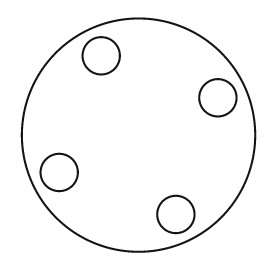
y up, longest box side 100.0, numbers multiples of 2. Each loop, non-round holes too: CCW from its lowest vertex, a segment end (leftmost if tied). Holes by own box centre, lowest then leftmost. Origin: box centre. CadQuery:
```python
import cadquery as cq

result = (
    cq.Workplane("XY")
    .moveTo(0.0, 0.0)
    .circle(50.0)
    .moveTo(16.0, -34.0)
    .circle(8.0)
    .moveTo(-34.0, -16.0)
    .circle(8.0)
    .moveTo(34.0, 16.0)
    .circle(8.0)
    .moveTo(-16.0, 34.0)
    .circle(8.0)
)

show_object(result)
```